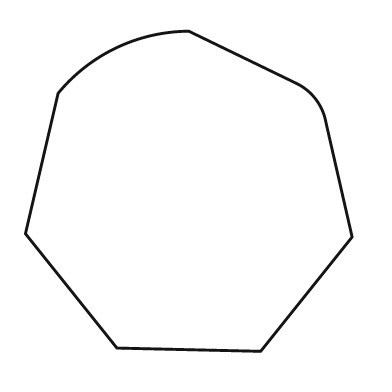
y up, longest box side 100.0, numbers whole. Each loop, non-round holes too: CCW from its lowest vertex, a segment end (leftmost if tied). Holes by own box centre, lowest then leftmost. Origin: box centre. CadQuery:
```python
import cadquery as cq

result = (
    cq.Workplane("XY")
    .moveTo(22.0, -49.0)
    .lineTo(50.0, -14.0)
    .lineTo(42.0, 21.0)
    .threePointArc((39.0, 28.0), (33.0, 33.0))
    .lineTo(0.0, 49.0)
    .threePointArc((-22.0, 44.0), (-40.0, 30.0))
    .lineTo(-50.0, -13.0)
    .lineTo(-22.0, -48.0)
    .close()
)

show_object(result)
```